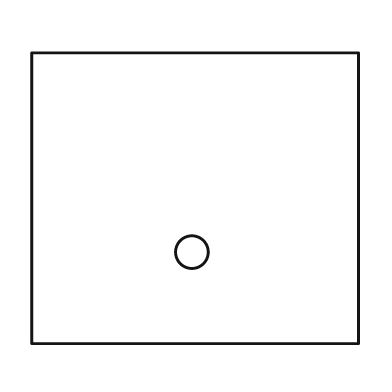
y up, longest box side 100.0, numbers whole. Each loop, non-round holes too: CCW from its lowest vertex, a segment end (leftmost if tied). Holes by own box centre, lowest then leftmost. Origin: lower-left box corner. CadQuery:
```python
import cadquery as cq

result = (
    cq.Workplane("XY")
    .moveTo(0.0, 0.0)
    .lineTo(100.0, 0.0)
    .lineTo(100.0, 89.0)
    .lineTo(0.0, 89.0)
    .close()
    .moveTo(49.0, 28.0)
    .circle(5.0)
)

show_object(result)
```